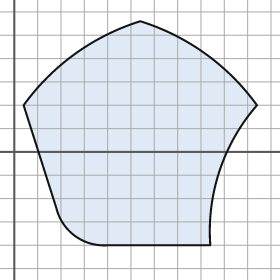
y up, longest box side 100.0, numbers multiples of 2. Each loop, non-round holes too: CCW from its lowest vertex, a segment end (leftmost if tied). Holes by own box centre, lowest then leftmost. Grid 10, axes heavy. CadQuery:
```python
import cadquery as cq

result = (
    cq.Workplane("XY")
    .moveTo(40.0, -40.0)
    .lineTo(84.0, -40.0)
    .threePointArc((88.0, -8.0), (104.0, 20.0))
    .threePointArc((82.0, 42.0), (54.0, 56.0))
    .threePointArc((26.0, 42.0), (4.0, 20.0))
    .lineTo(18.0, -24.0)
    .threePointArc((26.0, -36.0), (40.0, -40.0))
    .close()
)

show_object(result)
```